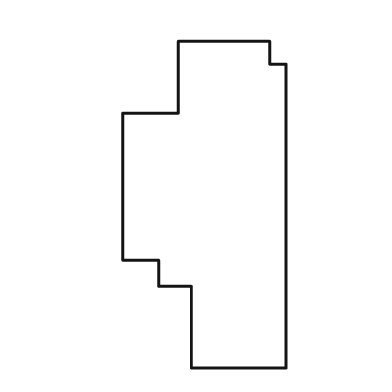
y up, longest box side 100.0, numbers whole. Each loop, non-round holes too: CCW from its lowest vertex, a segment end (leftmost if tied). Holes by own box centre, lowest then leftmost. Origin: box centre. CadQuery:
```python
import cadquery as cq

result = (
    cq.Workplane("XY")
    .moveTo(-4.0, -50.0)
    .lineTo(25.0, -50.0)
    .lineTo(25.0, 43.0)
    .lineTo(20.0, 43.0)
    .lineTo(20.0, 50.0)
    .lineTo(-8.0, 50.0)
    .lineTo(-8.0, 28.0)
    .lineTo(-25.0, 28.0)
    .lineTo(-25.0, -17.0)
    .lineTo(-14.0, -17.0)
    .lineTo(-14.0, -25.0)
    .lineTo(-4.0, -25.0)
    .close()
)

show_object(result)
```